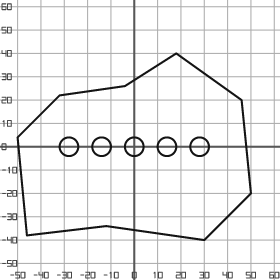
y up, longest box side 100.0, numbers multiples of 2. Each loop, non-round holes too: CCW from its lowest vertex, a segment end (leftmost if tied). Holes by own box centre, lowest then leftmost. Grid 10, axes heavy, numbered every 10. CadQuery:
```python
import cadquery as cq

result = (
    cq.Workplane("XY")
    .moveTo(30.0, -40.0)
    .lineTo(50.0, -20.0)
    .lineTo(46.0, 20.0)
    .lineTo(18.0, 40.0)
    .lineTo(-4.0, 26.0)
    .lineTo(-32.0, 22.0)
    .lineTo(-50.0, 4.0)
    .lineTo(-46.0, -38.0)
    .lineTo(-12.0, -34.0)
    .close()
    .moveTo(-28.0, 0.0)
    .circle(4.0)
    .moveTo(-14.0, 0.0)
    .circle(4.0)
    .moveTo(0.0, 0.0)
    .circle(4.0)
    .moveTo(14.0, 0.0)
    .circle(4.0)
    .moveTo(28.0, 0.0)
    .circle(4.0)
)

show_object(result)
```